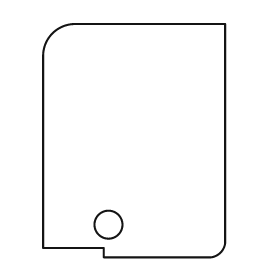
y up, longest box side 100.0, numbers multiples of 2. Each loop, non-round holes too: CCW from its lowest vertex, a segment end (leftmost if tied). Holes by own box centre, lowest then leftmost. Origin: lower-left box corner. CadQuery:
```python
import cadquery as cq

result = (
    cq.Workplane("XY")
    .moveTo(26.0, 0.0)
    .lineTo(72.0, 0.0)
    .threePointArc((76.0, 2.0), (78.0, 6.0))
    .lineTo(78.0, 100.0)
    .lineTo(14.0, 100.0)
    .threePointArc((4.0, 96.0), (0.0, 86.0))
    .lineTo(0.0, 4.0)
    .lineTo(26.0, 4.0)
    .close()
    .moveTo(28.0, 14.0)
    .circle(6.0)
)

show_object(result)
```